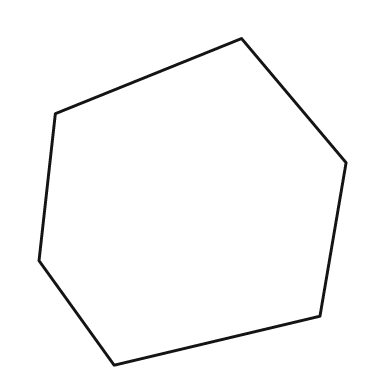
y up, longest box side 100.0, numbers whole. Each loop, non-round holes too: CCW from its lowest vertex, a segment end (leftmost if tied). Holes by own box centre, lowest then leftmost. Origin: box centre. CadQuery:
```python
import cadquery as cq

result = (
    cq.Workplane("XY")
    .moveTo(-24.0, -50.0)
    .lineTo(39.0, -35.0)
    .lineTo(47.0, 12.0)
    .lineTo(15.0, 50.0)
    .lineTo(-42.0, 27.0)
    .lineTo(-47.0, -18.0)
    .close()
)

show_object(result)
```